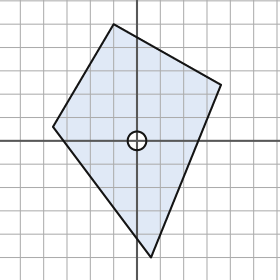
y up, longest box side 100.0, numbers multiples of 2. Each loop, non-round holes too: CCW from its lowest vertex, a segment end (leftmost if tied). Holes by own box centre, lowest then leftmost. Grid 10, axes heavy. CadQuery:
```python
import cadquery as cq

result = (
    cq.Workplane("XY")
    .moveTo(6.0, -50.0)
    .lineTo(36.0, 24.0)
    .lineTo(-10.0, 50.0)
    .lineTo(-36.0, 6.0)
    .close()
    .moveTo(0.0, 0.0)
    .circle(4.0)
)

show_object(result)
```